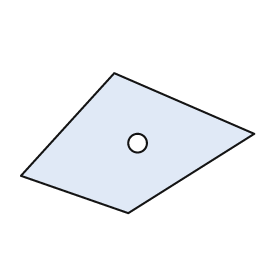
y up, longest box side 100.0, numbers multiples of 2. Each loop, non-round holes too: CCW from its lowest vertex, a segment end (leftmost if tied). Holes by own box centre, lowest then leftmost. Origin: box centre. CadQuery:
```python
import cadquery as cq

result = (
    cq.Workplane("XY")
    .moveTo(-4.0, -30.0)
    .lineTo(50.0, 4.0)
    .lineTo(-10.0, 30.0)
    .lineTo(-50.0, -14.0)
    .close()
    .moveTo(0.0, 0.0)
    .circle(4.0)
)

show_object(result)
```